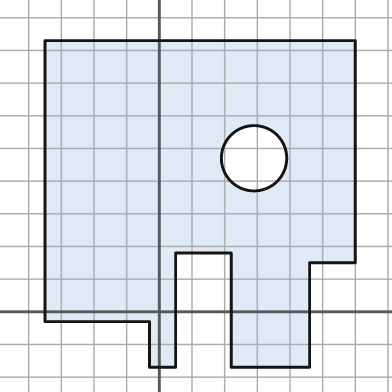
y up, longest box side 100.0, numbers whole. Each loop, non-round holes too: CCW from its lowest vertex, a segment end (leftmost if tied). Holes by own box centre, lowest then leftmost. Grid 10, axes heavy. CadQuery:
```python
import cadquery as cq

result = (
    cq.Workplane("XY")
    .moveTo(-3.0, -17.0)
    .lineTo(5.0, -17.0)
    .lineTo(5.0, 18.0)
    .lineTo(22.0, 18.0)
    .lineTo(22.0, -17.0)
    .lineTo(46.0, -17.0)
    .lineTo(46.0, 15.0)
    .lineTo(60.0, 15.0)
    .lineTo(60.0, 83.0)
    .lineTo(-35.0, 83.0)
    .lineTo(-35.0, -3.0)
    .lineTo(-3.0, -3.0)
    .close()
    .moveTo(29.0, 47.0)
    .circle(10.0)
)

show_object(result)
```